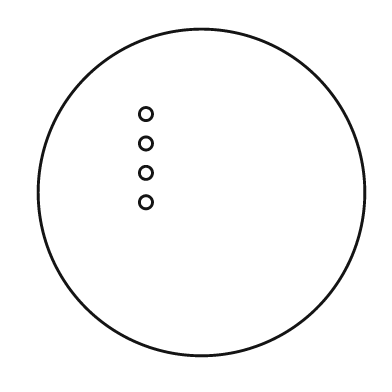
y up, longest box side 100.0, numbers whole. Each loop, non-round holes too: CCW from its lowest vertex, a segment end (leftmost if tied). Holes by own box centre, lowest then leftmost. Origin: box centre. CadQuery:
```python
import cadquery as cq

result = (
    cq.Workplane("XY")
    .moveTo(0.0, 0.0)
    .circle(50.0)
    .moveTo(-17.0, -3.0)
    .circle(2.0)
    .moveTo(-17.0, 6.0)
    .circle(2.0)
    .moveTo(-17.0, 15.0)
    .circle(2.0)
    .moveTo(-17.0, 24.0)
    .circle(2.0)
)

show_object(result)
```